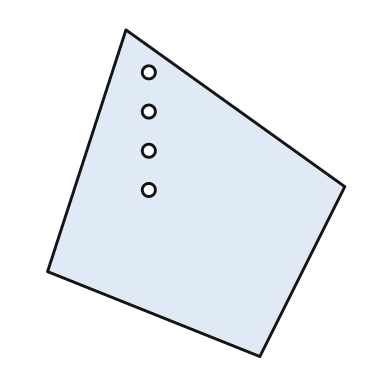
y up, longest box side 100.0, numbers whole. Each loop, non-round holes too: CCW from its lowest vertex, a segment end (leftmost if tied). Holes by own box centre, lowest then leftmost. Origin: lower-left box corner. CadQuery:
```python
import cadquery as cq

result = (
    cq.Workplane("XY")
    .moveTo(65.0, 0.0)
    .lineTo(91.0, 52.0)
    .lineTo(24.0, 100.0)
    .lineTo(0.0, 26.0)
    .close()
    .moveTo(31.0, 51.0)
    .circle(2.0)
    .moveTo(31.0, 63.0)
    .circle(2.0)
    .moveTo(31.0, 75.0)
    .circle(2.0)
    .moveTo(31.0, 87.0)
    .circle(2.0)
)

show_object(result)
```